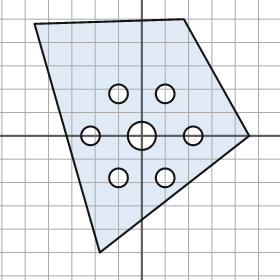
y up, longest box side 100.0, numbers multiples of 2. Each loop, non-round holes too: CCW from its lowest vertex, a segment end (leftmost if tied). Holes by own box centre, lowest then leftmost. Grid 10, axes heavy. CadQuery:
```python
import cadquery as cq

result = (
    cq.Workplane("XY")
    .moveTo(-18.0, -50.0)
    .lineTo(46.0, 0.0)
    .lineTo(18.0, 50.0)
    .lineTo(-46.0, 48.0)
    .close()
    .moveTo(-10.0, -18.0)
    .circle(4.0)
    .moveTo(10.0, -18.0)
    .circle(4.0)
    .moveTo(-22.0, 0.0)
    .circle(4.0)
    .moveTo(0.0, 0.0)
    .circle(6.0)
    .moveTo(22.0, 0.0)
    .circle(4.0)
    .moveTo(-10.0, 18.0)
    .circle(4.0)
    .moveTo(10.0, 18.0)
    .circle(4.0)
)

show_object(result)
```